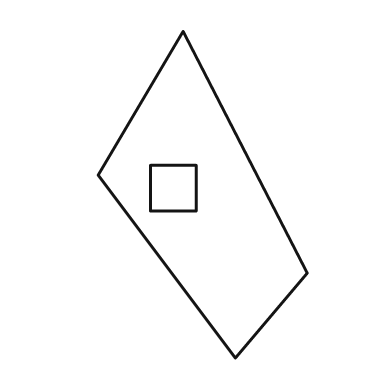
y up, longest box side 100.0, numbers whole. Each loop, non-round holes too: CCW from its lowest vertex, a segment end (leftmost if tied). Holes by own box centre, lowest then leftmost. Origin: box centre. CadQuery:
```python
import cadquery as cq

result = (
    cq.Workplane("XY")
    .moveTo(10.0, -50.0)
    .lineTo(32.0, -24.0)
    .lineTo(-6.0, 50.0)
    .lineTo(-32.0, 6.0)
    .close()
    .moveTo(-16.0, -5.0)
    .lineTo(-2.0, -5.0)
    .lineTo(-2.0, 9.0)
    .lineTo(-16.0, 9.0)
    .close()
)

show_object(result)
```